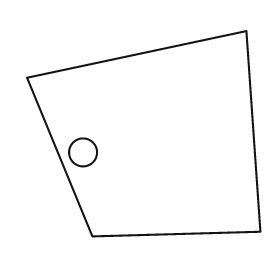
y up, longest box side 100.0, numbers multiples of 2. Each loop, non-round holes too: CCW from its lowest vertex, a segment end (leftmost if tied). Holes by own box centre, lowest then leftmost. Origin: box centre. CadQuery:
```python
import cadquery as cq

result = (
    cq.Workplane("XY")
    .moveTo(-22.0, -44.0)
    .lineTo(50.0, -42.0)
    .lineTo(44.0, 44.0)
    .lineTo(-50.0, 24.0)
    .close()
    .moveTo(-26.0, -8.0)
    .circle(6.0)
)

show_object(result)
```